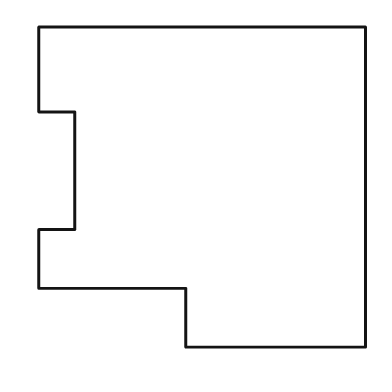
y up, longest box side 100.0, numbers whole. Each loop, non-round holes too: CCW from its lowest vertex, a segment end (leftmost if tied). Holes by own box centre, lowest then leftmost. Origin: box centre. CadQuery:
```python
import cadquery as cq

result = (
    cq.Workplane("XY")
    .moveTo(-5.0, -49.0)
    .lineTo(50.0, -49.0)
    .lineTo(50.0, 49.0)
    .lineTo(-50.0, 49.0)
    .lineTo(-50.0, 23.0)
    .lineTo(-39.0, 23.0)
    .lineTo(-39.0, -13.0)
    .lineTo(-50.0, -13.0)
    .lineTo(-50.0, -31.0)
    .lineTo(-5.0, -31.0)
    .close()
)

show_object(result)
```